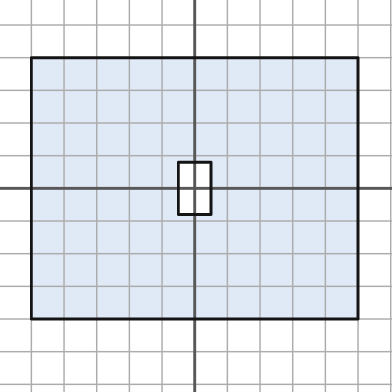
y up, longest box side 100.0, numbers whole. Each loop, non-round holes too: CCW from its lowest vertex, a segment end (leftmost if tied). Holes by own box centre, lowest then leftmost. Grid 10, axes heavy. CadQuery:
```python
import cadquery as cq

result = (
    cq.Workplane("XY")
    .moveTo(-50.0, -40.0)
    .lineTo(50.0, -40.0)
    .lineTo(50.0, 40.0)
    .lineTo(-50.0, 40.0)
    .close()
    .moveTo(-5.0, -8.0)
    .lineTo(5.0, -8.0)
    .lineTo(5.0, 8.0)
    .lineTo(-5.0, 8.0)
    .close()
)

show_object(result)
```